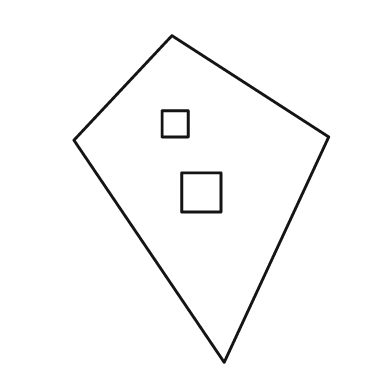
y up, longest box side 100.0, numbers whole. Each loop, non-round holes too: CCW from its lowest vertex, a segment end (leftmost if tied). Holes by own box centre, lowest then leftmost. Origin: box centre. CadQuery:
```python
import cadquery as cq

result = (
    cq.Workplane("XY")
    .moveTo(7.0, -50.0)
    .lineTo(39.0, 19.0)
    .lineTo(-9.0, 50.0)
    .lineTo(-39.0, 18.0)
    .close()
    .moveTo(-6.0, -4.0)
    .lineTo(6.0, -4.0)
    .lineTo(6.0, 8.0)
    .lineTo(-6.0, 8.0)
    .close()
    .moveTo(-12.0, 19.0)
    .lineTo(-4.0, 19.0)
    .lineTo(-4.0, 27.0)
    .lineTo(-12.0, 27.0)
    .close()
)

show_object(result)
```